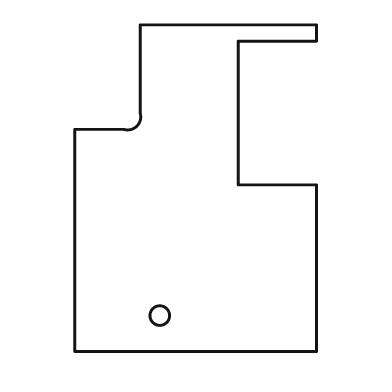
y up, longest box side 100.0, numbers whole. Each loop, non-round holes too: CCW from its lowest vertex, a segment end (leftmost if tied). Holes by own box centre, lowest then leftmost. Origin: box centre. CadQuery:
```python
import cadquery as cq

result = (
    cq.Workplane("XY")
    .moveTo(-37.0, -50.0)
    .lineTo(37.0, -50.0)
    .lineTo(37.0, 1.0)
    .lineTo(13.0, 1.0)
    .lineTo(13.0, 45.0)
    .lineTo(37.0, 45.0)
    .lineTo(37.0, 50.0)
    .lineTo(-17.0, 50.0)
    .lineTo(-17.0, 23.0)
    .threePointArc((-18.0, 19.0), (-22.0, 18.0))
    .lineTo(-37.0, 18.0)
    .close()
    .moveTo(-11.0, -39.0)
    .circle(3.0)
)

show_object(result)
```